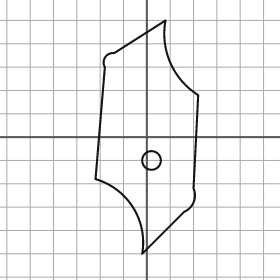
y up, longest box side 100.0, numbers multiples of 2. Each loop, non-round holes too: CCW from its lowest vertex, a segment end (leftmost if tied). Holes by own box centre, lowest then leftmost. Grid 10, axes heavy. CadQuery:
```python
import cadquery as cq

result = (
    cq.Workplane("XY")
    .moveTo(-2.0, -50.0)
    .lineTo(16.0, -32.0)
    .threePointArc((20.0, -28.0), (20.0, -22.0))
    .lineTo(22.0, 18.0)
    .threePointArc((10.0, 32.0), (8.0, 50.0))
    .lineTo(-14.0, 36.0)
    .threePointArc((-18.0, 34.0), (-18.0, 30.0))
    .lineTo(-22.0, -18.0)
    .threePointArc((-6.0, -30.0), (-2.0, -50.0))
    .close()
    .moveTo(2.0, -10.0)
    .circle(4.0)
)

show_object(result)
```